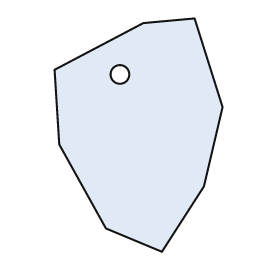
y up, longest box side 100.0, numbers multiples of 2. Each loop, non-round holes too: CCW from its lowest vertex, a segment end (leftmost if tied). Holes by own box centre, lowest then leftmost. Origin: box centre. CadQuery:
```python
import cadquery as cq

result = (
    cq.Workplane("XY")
    .moveTo(10.0, -50.0)
    .lineTo(28.0, -22.0)
    .lineTo(36.0, 12.0)
    .lineTo(24.0, 50.0)
    .lineTo(2.0, 48.0)
    .lineTo(-36.0, 28.0)
    .lineTo(-34.0, -4.0)
    .lineTo(-14.0, -40.0)
    .close()
    .moveTo(-8.0, 26.0)
    .circle(4.0)
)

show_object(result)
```